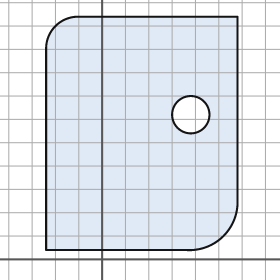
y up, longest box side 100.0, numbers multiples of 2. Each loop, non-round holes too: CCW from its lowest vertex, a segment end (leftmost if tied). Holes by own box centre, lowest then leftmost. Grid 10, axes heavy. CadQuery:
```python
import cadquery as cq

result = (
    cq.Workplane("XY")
    .moveTo(-24.0, 4.0)
    .lineTo(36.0, 4.0)
    .threePointArc((52.0, 10.0), (58.0, 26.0))
    .lineTo(58.0, 104.0)
    .lineTo(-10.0, 104.0)
    .threePointArc((-20.0, 100.0), (-24.0, 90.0))
    .close()
    .moveTo(38.0, 62.0)
    .circle(8.0)
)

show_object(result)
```